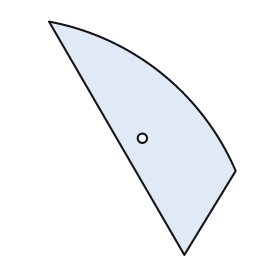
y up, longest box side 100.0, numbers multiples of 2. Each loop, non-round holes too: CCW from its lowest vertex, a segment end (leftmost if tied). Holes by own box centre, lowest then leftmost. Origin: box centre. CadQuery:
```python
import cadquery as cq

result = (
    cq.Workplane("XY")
    .moveTo(18.0, -50.0)
    .lineTo(40.0, -14.0)
    .threePointArc((8.0, 28.0), (-40.0, 50.0))
    .close()
    .moveTo(0.0, 0.0)
    .circle(2.0)
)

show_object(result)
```